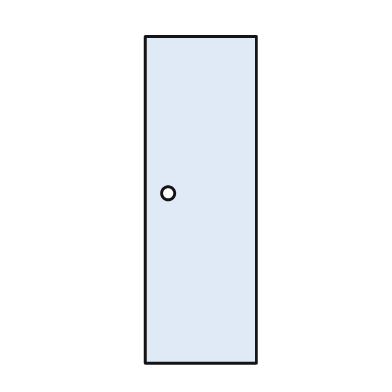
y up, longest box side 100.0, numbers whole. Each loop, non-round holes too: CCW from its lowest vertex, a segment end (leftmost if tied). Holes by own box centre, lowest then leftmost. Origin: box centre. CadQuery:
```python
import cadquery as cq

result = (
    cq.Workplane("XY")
    .moveTo(-17.0, -50.0)
    .lineTo(17.0, -50.0)
    .lineTo(17.0, 50.0)
    .lineTo(-17.0, 50.0)
    .close()
    .moveTo(-10.0, 2.0)
    .circle(2.0)
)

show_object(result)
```